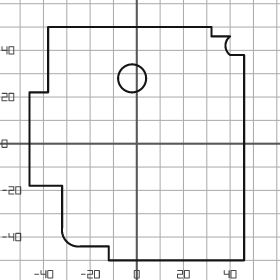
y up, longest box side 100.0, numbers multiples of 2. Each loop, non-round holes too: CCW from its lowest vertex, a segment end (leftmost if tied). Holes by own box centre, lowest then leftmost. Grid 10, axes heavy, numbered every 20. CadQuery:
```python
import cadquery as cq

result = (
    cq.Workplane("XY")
    .moveTo(-12.0, -50.0)
    .lineTo(46.0, -50.0)
    .lineTo(46.0, 38.0)
    .lineTo(40.0, 38.0)
    .threePointArc((38.0, 42.0), (40.0, 46.0))
    .lineTo(32.0, 46.0)
    .lineTo(32.0, 50.0)
    .lineTo(-38.0, 50.0)
    .lineTo(-38.0, 22.0)
    .lineTo(-46.0, 22.0)
    .lineTo(-46.0, -18.0)
    .lineTo(-32.0, -18.0)
    .lineTo(-32.0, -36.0)
    .threePointArc((-30.0, -42.0), (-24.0, -44.0))
    .lineTo(-12.0, -44.0)
    .close()
    .moveTo(-2.0, 28.0)
    .circle(6.0)
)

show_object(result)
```